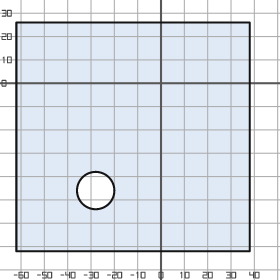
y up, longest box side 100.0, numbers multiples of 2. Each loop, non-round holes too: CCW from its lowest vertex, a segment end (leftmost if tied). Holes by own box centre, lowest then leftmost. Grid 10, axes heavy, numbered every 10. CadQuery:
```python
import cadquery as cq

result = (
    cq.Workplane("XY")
    .moveTo(-62.0, -72.0)
    .lineTo(38.0, -72.0)
    .lineTo(38.0, 26.0)
    .lineTo(-62.0, 26.0)
    .close()
    .moveTo(-28.0, -46.0)
    .circle(8.0)
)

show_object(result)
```